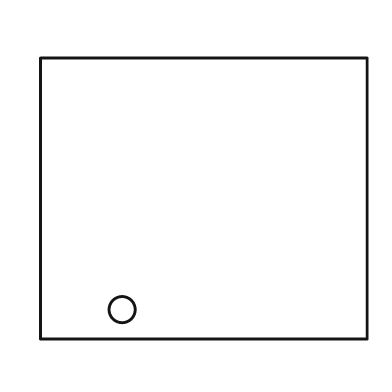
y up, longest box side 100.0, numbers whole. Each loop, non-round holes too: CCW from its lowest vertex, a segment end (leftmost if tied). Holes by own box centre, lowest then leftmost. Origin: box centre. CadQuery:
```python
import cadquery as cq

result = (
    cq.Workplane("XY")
    .moveTo(-50.0, -43.0)
    .lineTo(50.0, -43.0)
    .lineTo(50.0, 43.0)
    .lineTo(-50.0, 43.0)
    .close()
    .moveTo(-25.0, -34.0)
    .circle(4.0)
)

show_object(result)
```